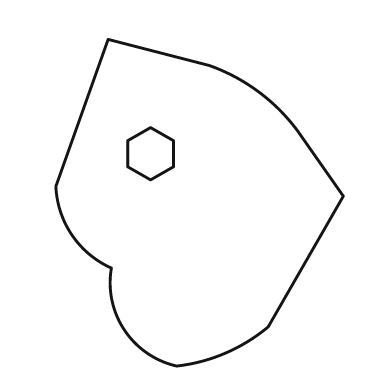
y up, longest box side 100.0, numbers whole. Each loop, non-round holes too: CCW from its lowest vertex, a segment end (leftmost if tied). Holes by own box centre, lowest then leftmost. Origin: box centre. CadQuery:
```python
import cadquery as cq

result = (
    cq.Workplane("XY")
    .moveTo(-7.0, -50.0)
    .threePointArc((8.0, -46.0), (21.0, -38.0))
    .lineTo(44.0, 2.0)
    .lineTo(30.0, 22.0)
    .threePointArc((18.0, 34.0), (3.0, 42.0))
    .lineTo(-28.0, 50.0)
    .lineTo(-44.0, 5.0)
    .threePointArc((-39.0, -10.0), (-27.0, -20.0))
    .threePointArc((-23.0, -39.0), (-7.0, -50.0))
    .close()
    .moveTo(-15.0, 7.0)
    .lineTo(-8.0, 11.0)
    .lineTo(-8.0, 19.0)
    .lineTo(-15.0, 23.0)
    .lineTo(-22.0, 19.0)
    .lineTo(-22.0, 11.0)
    .close()
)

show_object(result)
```